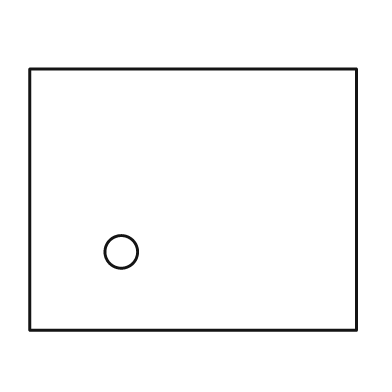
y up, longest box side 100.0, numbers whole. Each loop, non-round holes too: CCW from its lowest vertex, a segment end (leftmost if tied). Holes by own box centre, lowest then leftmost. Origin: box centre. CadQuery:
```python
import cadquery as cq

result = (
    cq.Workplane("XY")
    .moveTo(-50.0, -40.0)
    .lineTo(50.0, -40.0)
    .lineTo(50.0, 40.0)
    .lineTo(-50.0, 40.0)
    .close()
    .moveTo(-22.0, -16.0)
    .circle(5.0)
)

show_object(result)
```